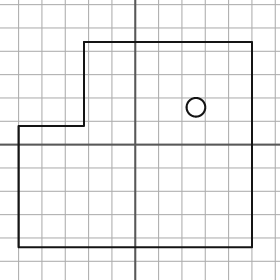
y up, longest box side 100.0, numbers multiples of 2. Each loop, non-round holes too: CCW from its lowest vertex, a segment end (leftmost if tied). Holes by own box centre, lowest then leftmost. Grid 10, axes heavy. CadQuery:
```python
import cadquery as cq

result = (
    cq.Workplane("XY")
    .moveTo(-50.0, -44.0)
    .lineTo(50.0, -44.0)
    .lineTo(50.0, 44.0)
    .lineTo(-22.0, 44.0)
    .lineTo(-22.0, 8.0)
    .lineTo(-50.0, 8.0)
    .close()
    .moveTo(26.0, 16.0)
    .circle(4.0)
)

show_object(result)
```